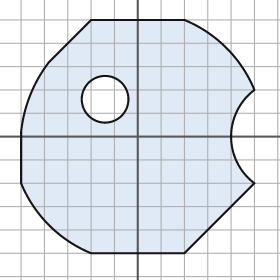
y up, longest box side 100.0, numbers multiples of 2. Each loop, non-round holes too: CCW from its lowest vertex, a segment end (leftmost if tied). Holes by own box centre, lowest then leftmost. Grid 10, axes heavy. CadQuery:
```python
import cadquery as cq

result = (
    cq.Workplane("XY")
    .moveTo(-20.0, -50.0)
    .lineTo(20.0, -50.0)
    .lineTo(50.0, -20.0)
    .threePointArc((40.0, 0.0), (50.0, 20.0))
    .threePointArc((38.0, 38.0), (20.0, 50.0))
    .lineTo(-20.0, 50.0)
    .lineTo(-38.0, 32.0)
    .threePointArc((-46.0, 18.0), (-50.0, 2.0))
    .lineTo(-50.0, -20.0)
    .threePointArc((-38.0, -38.0), (-20.0, -50.0))
    .close()
    .moveTo(-14.0, 16.0)
    .circle(10.0)
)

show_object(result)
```